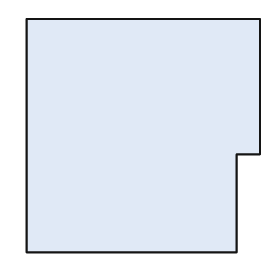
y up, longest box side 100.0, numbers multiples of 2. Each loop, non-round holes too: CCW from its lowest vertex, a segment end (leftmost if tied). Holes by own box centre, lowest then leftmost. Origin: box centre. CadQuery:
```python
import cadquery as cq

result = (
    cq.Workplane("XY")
    .moveTo(-50.0, -50.0)
    .lineTo(40.0, -50.0)
    .lineTo(40.0, -8.0)
    .lineTo(50.0, -8.0)
    .lineTo(50.0, 50.0)
    .lineTo(-50.0, 50.0)
    .close()
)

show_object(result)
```